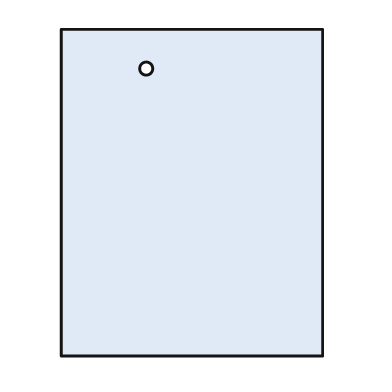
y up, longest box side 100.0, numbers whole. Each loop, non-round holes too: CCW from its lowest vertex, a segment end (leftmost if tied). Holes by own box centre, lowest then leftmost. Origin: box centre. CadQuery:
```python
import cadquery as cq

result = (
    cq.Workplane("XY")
    .moveTo(-40.0, -50.0)
    .lineTo(40.0, -50.0)
    .lineTo(40.0, 50.0)
    .lineTo(-40.0, 50.0)
    .close()
    .moveTo(-14.0, 38.0)
    .circle(2.0)
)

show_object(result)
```